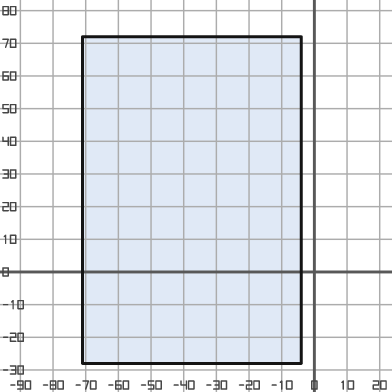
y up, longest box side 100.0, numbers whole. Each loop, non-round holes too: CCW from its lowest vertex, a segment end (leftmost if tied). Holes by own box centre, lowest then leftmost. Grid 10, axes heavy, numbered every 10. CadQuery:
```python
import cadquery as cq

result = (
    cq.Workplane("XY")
    .moveTo(-71.0, -28.0)
    .lineTo(-4.0, -28.0)
    .lineTo(-4.0, 72.0)
    .lineTo(-71.0, 72.0)
    .close()
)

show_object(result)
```